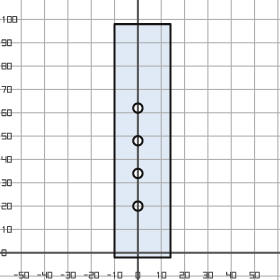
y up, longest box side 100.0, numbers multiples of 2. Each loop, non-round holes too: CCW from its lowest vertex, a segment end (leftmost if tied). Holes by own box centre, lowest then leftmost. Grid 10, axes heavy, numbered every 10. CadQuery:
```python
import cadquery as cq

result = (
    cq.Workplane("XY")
    .moveTo(-10.0, -2.0)
    .lineTo(14.0, -2.0)
    .lineTo(14.0, 98.0)
    .lineTo(-10.0, 98.0)
    .close()
    .moveTo(0.0, 20.0)
    .circle(2.0)
    .moveTo(0.0, 34.0)
    .circle(2.0)
    .moveTo(0.0, 48.0)
    .circle(2.0)
    .moveTo(0.0, 62.0)
    .circle(2.0)
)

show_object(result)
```